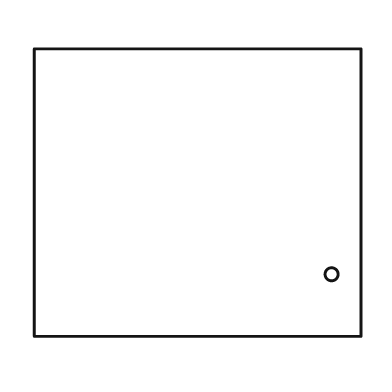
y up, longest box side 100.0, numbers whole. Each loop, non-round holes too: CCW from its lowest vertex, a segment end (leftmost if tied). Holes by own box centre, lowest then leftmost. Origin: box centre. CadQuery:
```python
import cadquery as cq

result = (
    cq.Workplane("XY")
    .moveTo(-50.0, -44.0)
    .lineTo(50.0, -44.0)
    .lineTo(50.0, 44.0)
    .lineTo(-50.0, 44.0)
    .close()
    .moveTo(41.0, -25.0)
    .circle(2.0)
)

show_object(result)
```